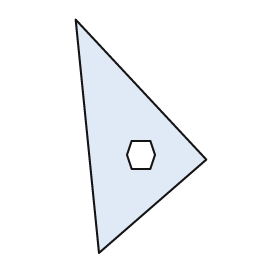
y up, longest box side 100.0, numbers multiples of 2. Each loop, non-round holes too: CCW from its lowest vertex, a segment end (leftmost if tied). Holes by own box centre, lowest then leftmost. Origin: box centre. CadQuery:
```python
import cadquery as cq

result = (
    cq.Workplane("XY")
    .moveTo(-18.0, -50.0)
    .lineTo(28.0, -10.0)
    .lineTo(-28.0, 50.0)
    .close()
    .moveTo(-4.0, -14.0)
    .lineTo(4.0, -14.0)
    .lineTo(6.0, -8.0)
    .lineTo(4.0, -2.0)
    .lineTo(-4.0, -2.0)
    .lineTo(-6.0, -8.0)
    .close()
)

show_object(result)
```